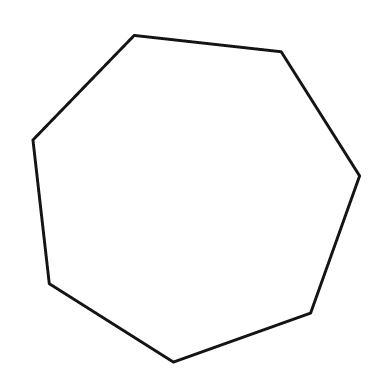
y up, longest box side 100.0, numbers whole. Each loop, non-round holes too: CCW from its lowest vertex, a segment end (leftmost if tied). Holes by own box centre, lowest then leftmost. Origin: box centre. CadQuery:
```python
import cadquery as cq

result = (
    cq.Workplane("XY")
    .moveTo(-7.0, -50.0)
    .lineTo(35.0, -35.0)
    .lineTo(50.0, 7.0)
    .lineTo(26.0, 45.0)
    .lineTo(-19.0, 50.0)
    .lineTo(-50.0, 18.0)
    .lineTo(-45.0, -26.0)
    .close()
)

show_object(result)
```